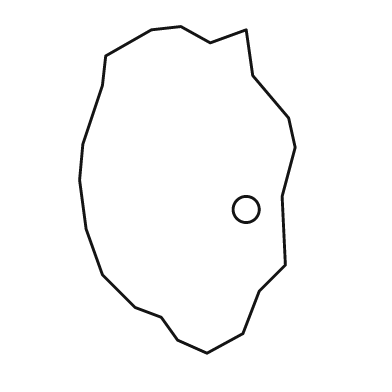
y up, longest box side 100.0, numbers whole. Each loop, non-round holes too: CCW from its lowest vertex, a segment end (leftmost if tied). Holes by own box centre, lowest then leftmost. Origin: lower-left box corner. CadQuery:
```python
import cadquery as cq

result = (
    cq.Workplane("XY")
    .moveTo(39.0, 0.0)
    .lineTo(50.0, 6.0)
    .lineTo(55.0, 19.0)
    .lineTo(63.0, 27.0)
    .lineTo(62.0, 48.0)
    .lineTo(66.0, 63.0)
    .lineTo(64.0, 72.0)
    .lineTo(53.0, 85.0)
    .lineTo(51.0, 99.0)
    .lineTo(40.0, 95.0)
    .lineTo(31.0, 100.0)
    .lineTo(22.0, 99.0)
    .lineTo(8.0, 91.0)
    .lineTo(7.0, 82.0)
    .lineTo(1.0, 64.0)
    .lineTo(0.0, 53.0)
    .lineTo(2.0, 38.0)
    .lineTo(7.0, 24.0)
    .lineTo(17.0, 14.0)
    .lineTo(25.0, 11.0)
    .lineTo(30.0, 4.0)
    .close()
    .moveTo(51.0, 44.0)
    .circle(4.0)
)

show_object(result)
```